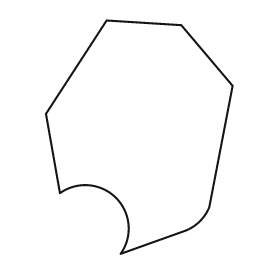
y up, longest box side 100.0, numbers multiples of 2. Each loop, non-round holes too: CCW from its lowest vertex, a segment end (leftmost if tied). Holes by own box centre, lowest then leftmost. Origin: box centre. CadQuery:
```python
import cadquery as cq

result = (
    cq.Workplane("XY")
    .moveTo(-8.0, -50.0)
    .lineTo(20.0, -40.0)
    .threePointArc((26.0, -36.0), (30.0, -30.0))
    .lineTo(40.0, 22.0)
    .lineTo(18.0, 48.0)
    .lineTo(-14.0, 50.0)
    .lineTo(-40.0, 10.0)
    .lineTo(-34.0, -24.0)
    .threePointArc((-10.0, -26.0), (-8.0, -50.0))
    .close()
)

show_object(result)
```